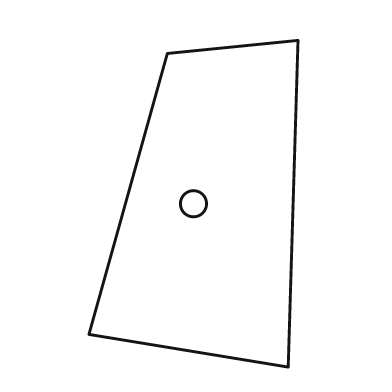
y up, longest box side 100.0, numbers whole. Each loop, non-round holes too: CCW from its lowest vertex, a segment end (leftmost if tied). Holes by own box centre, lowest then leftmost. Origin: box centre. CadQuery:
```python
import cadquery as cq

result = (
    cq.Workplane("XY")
    .moveTo(29.0, -50.0)
    .lineTo(32.0, 50.0)
    .lineTo(-8.0, 46.0)
    .lineTo(-32.0, -40.0)
    .close()
    .moveTo(0.0, 0.0)
    .circle(4.0)
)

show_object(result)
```